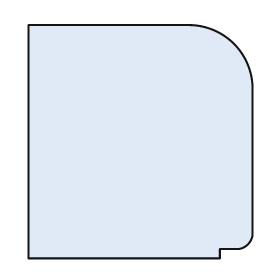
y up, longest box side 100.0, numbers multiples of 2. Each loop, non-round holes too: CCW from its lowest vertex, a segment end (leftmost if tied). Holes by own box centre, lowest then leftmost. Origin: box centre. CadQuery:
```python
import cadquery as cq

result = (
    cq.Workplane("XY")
    .moveTo(-48.0, -50.0)
    .lineTo(34.0, -50.0)
    .lineTo(34.0, -46.0)
    .lineTo(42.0, -46.0)
    .threePointArc((46.0, -44.0), (48.0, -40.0))
    .lineTo(48.0, 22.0)
    .threePointArc((40.0, 42.0), (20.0, 50.0))
    .lineTo(-48.0, 50.0)
    .close()
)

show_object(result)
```